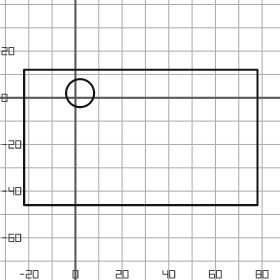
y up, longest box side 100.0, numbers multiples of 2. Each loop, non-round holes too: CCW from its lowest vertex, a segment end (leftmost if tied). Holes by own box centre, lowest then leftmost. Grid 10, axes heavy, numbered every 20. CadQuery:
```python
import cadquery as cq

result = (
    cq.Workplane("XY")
    .moveTo(-22.0, -46.0)
    .lineTo(78.0, -46.0)
    .lineTo(78.0, 12.0)
    .lineTo(-22.0, 12.0)
    .close()
    .moveTo(2.0, 2.0)
    .circle(6.0)
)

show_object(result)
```